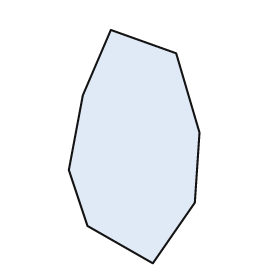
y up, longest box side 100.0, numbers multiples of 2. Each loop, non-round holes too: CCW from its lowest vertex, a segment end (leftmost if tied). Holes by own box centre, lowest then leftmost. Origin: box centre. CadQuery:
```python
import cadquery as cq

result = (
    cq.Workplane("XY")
    .moveTo(8.0, -50.0)
    .lineTo(26.0, -24.0)
    .lineTo(28.0, 6.0)
    .lineTo(18.0, 40.0)
    .lineTo(-10.0, 50.0)
    .lineTo(-22.0, 22.0)
    .lineTo(-28.0, -10.0)
    .lineTo(-20.0, -34.0)
    .close()
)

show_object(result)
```